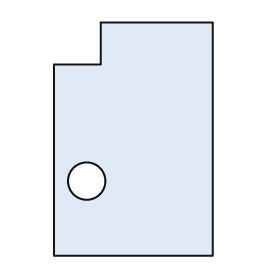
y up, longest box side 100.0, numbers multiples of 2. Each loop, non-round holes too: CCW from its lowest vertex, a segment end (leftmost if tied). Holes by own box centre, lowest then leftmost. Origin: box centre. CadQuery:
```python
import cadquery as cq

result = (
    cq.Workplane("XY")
    .moveTo(-34.0, -50.0)
    .lineTo(34.0, -50.0)
    .lineTo(34.0, 50.0)
    .lineTo(-14.0, 50.0)
    .lineTo(-14.0, 32.0)
    .lineTo(-34.0, 32.0)
    .close()
    .moveTo(-20.0, -18.0)
    .circle(8.0)
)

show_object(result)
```